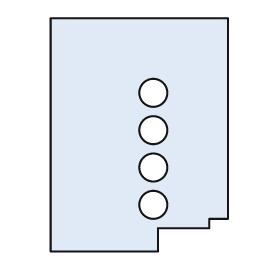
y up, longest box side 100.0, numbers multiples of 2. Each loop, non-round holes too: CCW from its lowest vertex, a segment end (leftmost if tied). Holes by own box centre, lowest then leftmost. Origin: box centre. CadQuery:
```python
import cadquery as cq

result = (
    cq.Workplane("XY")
    .moveTo(-38.0, -50.0)
    .lineTo(8.0, -50.0)
    .lineTo(8.0, -40.0)
    .lineTo(30.0, -40.0)
    .lineTo(30.0, -36.0)
    .lineTo(38.0, -36.0)
    .lineTo(38.0, 50.0)
    .lineTo(-38.0, 50.0)
    .close()
    .moveTo(6.0, -30.0)
    .circle(6.0)
    .moveTo(6.0, -14.0)
    .circle(6.0)
    .moveTo(6.0, 2.0)
    .circle(6.0)
    .moveTo(6.0, 18.0)
    .circle(6.0)
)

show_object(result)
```